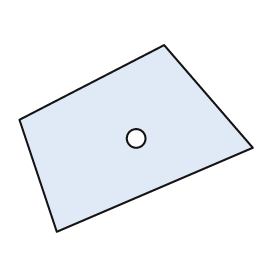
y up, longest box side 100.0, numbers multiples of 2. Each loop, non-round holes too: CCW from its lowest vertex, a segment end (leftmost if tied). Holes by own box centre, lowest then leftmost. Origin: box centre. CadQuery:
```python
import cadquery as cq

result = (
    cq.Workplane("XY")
    .moveTo(-34.0, -40.0)
    .lineTo(50.0, -4.0)
    .lineTo(12.0, 40.0)
    .lineTo(-50.0, 8.0)
    .close()
    .moveTo(0.0, 0.0)
    .circle(4.0)
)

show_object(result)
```